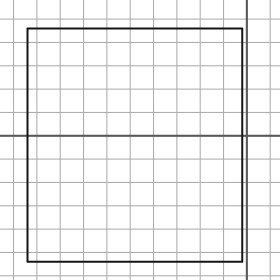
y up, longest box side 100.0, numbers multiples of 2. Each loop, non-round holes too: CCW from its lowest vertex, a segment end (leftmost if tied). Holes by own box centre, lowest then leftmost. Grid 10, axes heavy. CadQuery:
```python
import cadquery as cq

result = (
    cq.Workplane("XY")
    .moveTo(-94.0, -54.0)
    .lineTo(-2.0, -54.0)
    .lineTo(-2.0, 46.0)
    .lineTo(-94.0, 46.0)
    .close()
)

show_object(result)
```